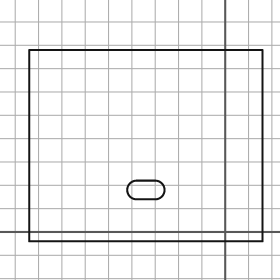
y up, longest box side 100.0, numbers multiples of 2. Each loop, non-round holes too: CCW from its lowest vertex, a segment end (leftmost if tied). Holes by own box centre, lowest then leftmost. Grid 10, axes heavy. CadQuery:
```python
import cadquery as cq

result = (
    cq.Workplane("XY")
    .moveTo(-84.0, -4.0)
    .lineTo(16.0, -4.0)
    .lineTo(16.0, 78.0)
    .lineTo(-84.0, 78.0)
    .close()
    .moveTo(-38.0, 14.0)
    .lineTo(-30.0, 14.0)
    .threePointArc((-26.0, 18.0), (-30.0, 22.0))
    .lineTo(-38.0, 22.0)
    .threePointArc((-42.0, 18.0), (-38.0, 14.0))
    .close()
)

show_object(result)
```